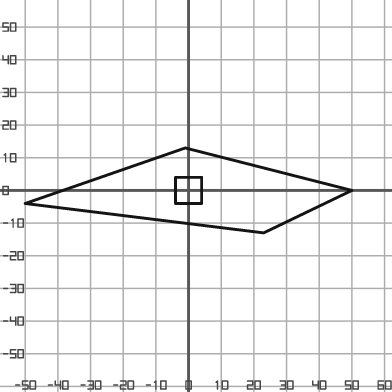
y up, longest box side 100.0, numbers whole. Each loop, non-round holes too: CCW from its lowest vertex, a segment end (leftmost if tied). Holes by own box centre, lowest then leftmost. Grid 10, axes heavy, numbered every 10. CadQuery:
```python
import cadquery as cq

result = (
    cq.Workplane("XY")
    .moveTo(23.0, -13.0)
    .lineTo(50.0, 0.0)
    .lineTo(-1.0, 13.0)
    .lineTo(-50.0, -4.0)
    .close()
    .moveTo(-4.0, -4.0)
    .lineTo(4.0, -4.0)
    .lineTo(4.0, 4.0)
    .lineTo(-4.0, 4.0)
    .close()
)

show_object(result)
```